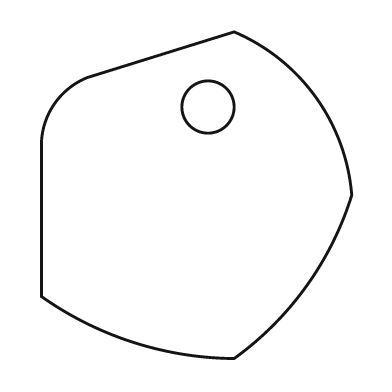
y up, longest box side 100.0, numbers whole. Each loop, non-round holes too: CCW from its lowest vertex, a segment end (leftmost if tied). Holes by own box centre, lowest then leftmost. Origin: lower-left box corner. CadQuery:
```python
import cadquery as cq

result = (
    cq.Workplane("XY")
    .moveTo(59.0, 0.0)
    .threePointArc((81.0, 22.0), (95.0, 50.0))
    .threePointArc((84.0, 80.0), (59.0, 100.0))
    .lineTo(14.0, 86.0)
    .threePointArc((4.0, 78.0), (0.0, 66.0))
    .lineTo(0.0, 19.0)
    .threePointArc((28.0, 5.0), (59.0, 0.0))
    .close()
    .moveTo(51.0, 77.0)
    .circle(8.0)
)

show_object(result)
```